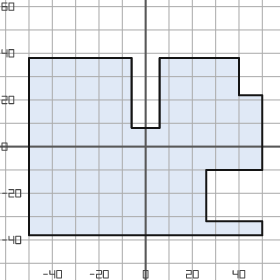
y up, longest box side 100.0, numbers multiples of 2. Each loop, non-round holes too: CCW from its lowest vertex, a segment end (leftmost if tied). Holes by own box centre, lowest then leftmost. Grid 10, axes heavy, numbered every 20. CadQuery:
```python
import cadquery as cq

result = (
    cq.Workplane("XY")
    .moveTo(-50.0, -38.0)
    .lineTo(50.0, -38.0)
    .lineTo(50.0, -32.0)
    .lineTo(26.0, -32.0)
    .lineTo(26.0, -10.0)
    .lineTo(50.0, -10.0)
    .lineTo(50.0, 22.0)
    .lineTo(40.0, 22.0)
    .lineTo(40.0, 38.0)
    .lineTo(6.0, 38.0)
    .lineTo(6.0, 8.0)
    .lineTo(-6.0, 8.0)
    .lineTo(-6.0, 38.0)
    .lineTo(-50.0, 38.0)
    .close()
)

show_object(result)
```